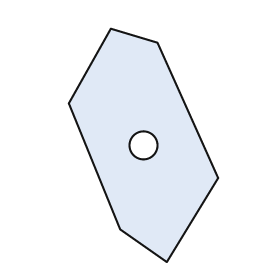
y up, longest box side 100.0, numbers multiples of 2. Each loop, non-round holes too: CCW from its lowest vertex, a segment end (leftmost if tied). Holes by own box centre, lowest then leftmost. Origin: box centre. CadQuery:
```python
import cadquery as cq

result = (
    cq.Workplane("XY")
    .moveTo(10.0, -50.0)
    .lineTo(32.0, -14.0)
    .lineTo(6.0, 44.0)
    .lineTo(-14.0, 50.0)
    .lineTo(-32.0, 18.0)
    .lineTo(-10.0, -36.0)
    .close()
    .moveTo(0.0, 0.0)
    .circle(6.0)
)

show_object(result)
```